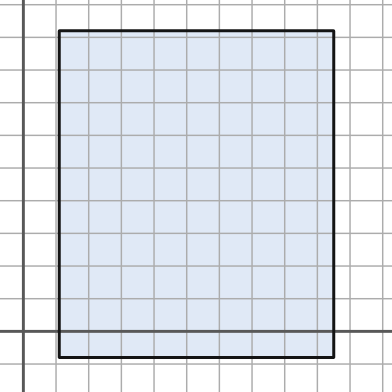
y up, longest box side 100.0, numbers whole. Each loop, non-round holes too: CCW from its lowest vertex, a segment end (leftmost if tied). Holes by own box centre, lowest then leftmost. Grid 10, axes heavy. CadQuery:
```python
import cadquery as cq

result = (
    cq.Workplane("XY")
    .moveTo(11.0, -8.0)
    .lineTo(95.0, -8.0)
    .lineTo(95.0, 92.0)
    .lineTo(11.0, 92.0)
    .close()
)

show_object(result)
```